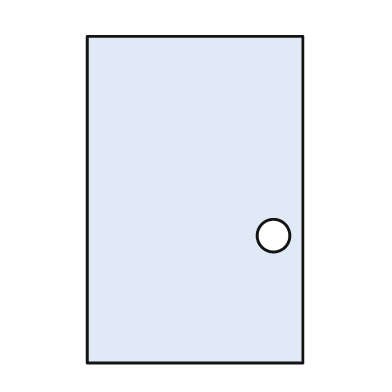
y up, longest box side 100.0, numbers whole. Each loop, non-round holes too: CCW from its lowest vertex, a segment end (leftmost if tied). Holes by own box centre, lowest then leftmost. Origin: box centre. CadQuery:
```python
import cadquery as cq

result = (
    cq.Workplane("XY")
    .moveTo(-33.0, -50.0)
    .lineTo(33.0, -50.0)
    .lineTo(33.0, 50.0)
    .lineTo(-33.0, 50.0)
    .close()
    .moveTo(24.0, -11.0)
    .circle(5.0)
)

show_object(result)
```